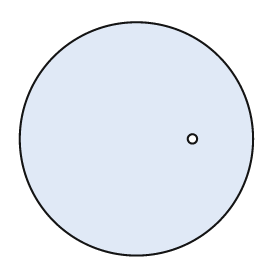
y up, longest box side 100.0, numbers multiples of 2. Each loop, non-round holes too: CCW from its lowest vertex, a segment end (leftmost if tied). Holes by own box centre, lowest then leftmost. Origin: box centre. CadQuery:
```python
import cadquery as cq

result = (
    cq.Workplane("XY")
    .moveTo(0.0, 0.0)
    .circle(50.0)
    .moveTo(24.0, 0.0)
    .circle(2.0)
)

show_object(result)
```